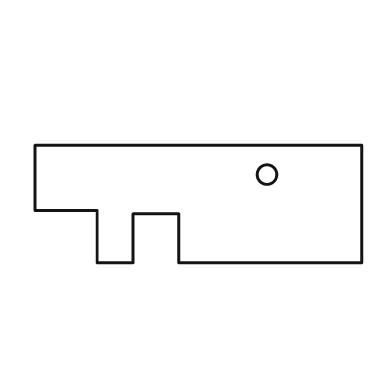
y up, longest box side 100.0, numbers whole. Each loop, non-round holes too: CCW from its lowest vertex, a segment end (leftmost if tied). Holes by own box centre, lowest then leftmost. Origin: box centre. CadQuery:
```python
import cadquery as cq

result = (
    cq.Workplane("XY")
    .moveTo(-31.0, -18.0)
    .lineTo(-20.0, -18.0)
    .lineTo(-20.0, -3.0)
    .lineTo(-6.0, -3.0)
    .lineTo(-6.0, -18.0)
    .lineTo(50.0, -18.0)
    .lineTo(50.0, 18.0)
    .lineTo(-50.0, 18.0)
    .lineTo(-50.0, -2.0)
    .lineTo(-31.0, -2.0)
    .close()
    .moveTo(21.0, 9.0)
    .circle(3.0)
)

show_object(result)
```